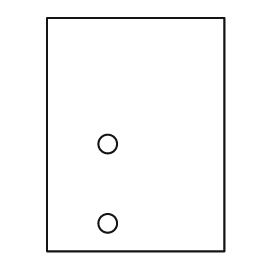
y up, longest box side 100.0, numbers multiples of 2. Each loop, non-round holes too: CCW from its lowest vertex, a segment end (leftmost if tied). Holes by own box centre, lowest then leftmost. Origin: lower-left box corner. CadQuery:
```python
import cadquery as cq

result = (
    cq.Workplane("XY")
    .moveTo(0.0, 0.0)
    .lineTo(76.0, 0.0)
    .lineTo(76.0, 100.0)
    .lineTo(0.0, 100.0)
    .close()
    .moveTo(26.0, 12.0)
    .circle(4.0)
    .moveTo(26.0, 46.0)
    .circle(4.0)
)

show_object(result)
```